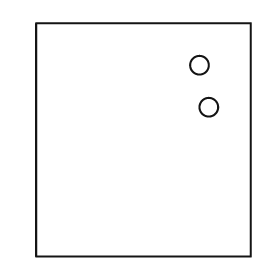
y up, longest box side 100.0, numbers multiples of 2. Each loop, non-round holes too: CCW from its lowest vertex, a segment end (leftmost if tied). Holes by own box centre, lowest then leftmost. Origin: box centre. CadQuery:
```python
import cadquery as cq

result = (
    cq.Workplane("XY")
    .moveTo(-46.0, -50.0)
    .lineTo(46.0, -50.0)
    .lineTo(46.0, 50.0)
    .lineTo(-46.0, 50.0)
    .close()
    .moveTo(28.0, 14.0)
    .circle(4.0)
    .moveTo(24.0, 32.0)
    .circle(4.0)
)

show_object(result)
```